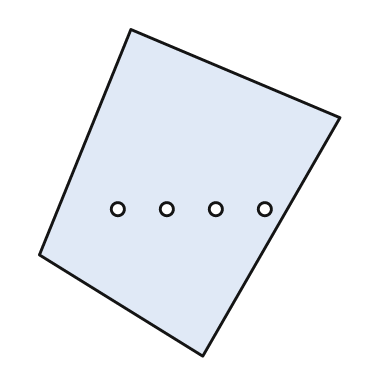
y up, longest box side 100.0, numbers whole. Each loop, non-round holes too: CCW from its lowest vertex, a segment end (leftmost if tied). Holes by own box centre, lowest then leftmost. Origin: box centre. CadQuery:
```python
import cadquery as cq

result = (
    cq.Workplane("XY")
    .moveTo(4.0, -50.0)
    .lineTo(46.0, 23.0)
    .lineTo(-18.0, 50.0)
    .lineTo(-46.0, -19.0)
    .close()
    .moveTo(-22.0, -5.0)
    .circle(2.0)
    .moveTo(-7.0, -5.0)
    .circle(2.0)
    .moveTo(8.0, -5.0)
    .circle(2.0)
    .moveTo(23.0, -5.0)
    .circle(2.0)
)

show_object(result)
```